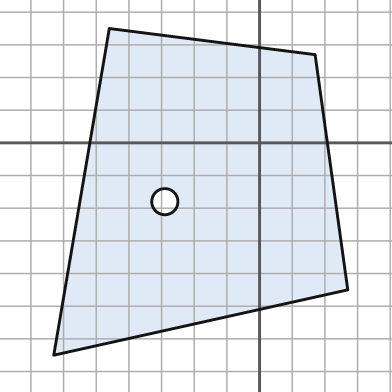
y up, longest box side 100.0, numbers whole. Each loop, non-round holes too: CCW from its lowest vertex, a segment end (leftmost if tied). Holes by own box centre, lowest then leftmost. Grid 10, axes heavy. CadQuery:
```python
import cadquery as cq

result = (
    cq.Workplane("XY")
    .moveTo(-63.0, -65.0)
    .lineTo(27.0, -45.0)
    .lineTo(17.0, 27.0)
    .lineTo(-46.0, 35.0)
    .close()
    .moveTo(-29.0, -18.0)
    .circle(4.0)
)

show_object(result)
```